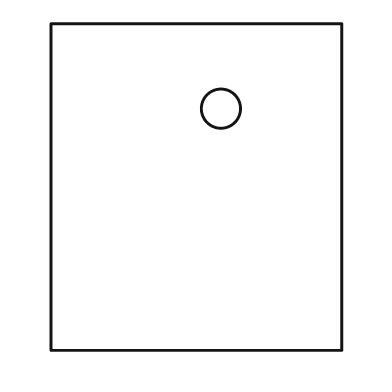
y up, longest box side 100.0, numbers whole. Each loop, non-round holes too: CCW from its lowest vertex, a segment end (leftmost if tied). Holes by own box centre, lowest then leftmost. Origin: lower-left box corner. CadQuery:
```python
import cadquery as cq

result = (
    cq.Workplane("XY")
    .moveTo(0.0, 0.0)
    .lineTo(89.0, 0.0)
    .lineTo(89.0, 100.0)
    .lineTo(0.0, 100.0)
    .close()
    .moveTo(52.0, 74.0)
    .circle(6.0)
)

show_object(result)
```